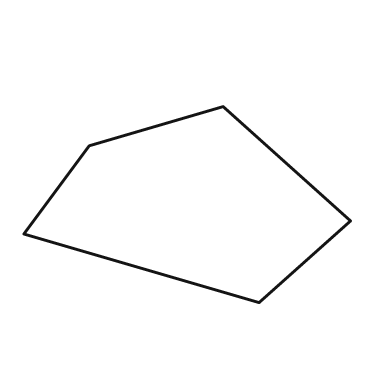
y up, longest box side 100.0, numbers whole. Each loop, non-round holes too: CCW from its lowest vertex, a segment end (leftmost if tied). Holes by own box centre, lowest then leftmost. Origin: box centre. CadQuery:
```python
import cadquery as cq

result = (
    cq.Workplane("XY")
    .moveTo(22.0, -30.0)
    .lineTo(50.0, -5.0)
    .lineTo(11.0, 30.0)
    .lineTo(-30.0, 18.0)
    .lineTo(-50.0, -9.0)
    .close()
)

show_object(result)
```